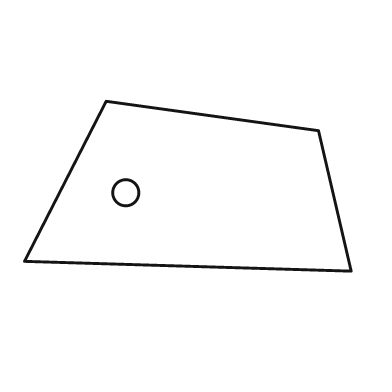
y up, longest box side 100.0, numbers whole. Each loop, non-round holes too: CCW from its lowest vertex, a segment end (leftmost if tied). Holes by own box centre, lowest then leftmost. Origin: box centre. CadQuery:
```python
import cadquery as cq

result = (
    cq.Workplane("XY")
    .moveTo(50.0, -26.0)
    .lineTo(40.0, 17.0)
    .lineTo(-25.0, 26.0)
    .lineTo(-50.0, -23.0)
    .close()
    .moveTo(-19.0, -2.0)
    .circle(4.0)
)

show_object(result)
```